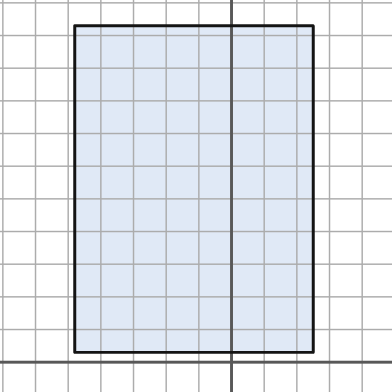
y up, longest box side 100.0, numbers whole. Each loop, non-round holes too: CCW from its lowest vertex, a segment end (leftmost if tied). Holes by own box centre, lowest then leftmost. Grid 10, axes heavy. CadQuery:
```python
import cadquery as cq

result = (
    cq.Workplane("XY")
    .moveTo(-48.0, 3.0)
    .lineTo(25.0, 3.0)
    .lineTo(25.0, 103.0)
    .lineTo(-48.0, 103.0)
    .close()
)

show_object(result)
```